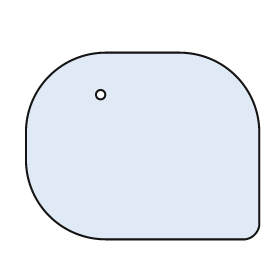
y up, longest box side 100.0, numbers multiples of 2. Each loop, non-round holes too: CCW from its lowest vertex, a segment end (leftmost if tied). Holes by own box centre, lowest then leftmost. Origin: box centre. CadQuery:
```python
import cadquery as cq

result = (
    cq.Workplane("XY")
    .moveTo(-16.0, -40.0)
    .lineTo(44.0, -40.0)
    .threePointArc((48.0, -38.0), (50.0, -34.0))
    .lineTo(50.0, 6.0)
    .threePointArc((40.0, 30.0), (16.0, 40.0))
    .lineTo(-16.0, 40.0)
    .threePointArc((-40.0, 30.0), (-50.0, 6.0))
    .lineTo(-50.0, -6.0)
    .threePointArc((-40.0, -30.0), (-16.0, -40.0))
    .close()
    .moveTo(-18.0, 22.0)
    .circle(2.0)
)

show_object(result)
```